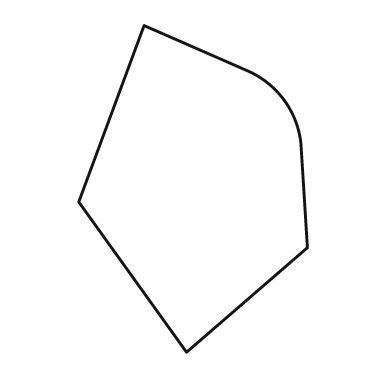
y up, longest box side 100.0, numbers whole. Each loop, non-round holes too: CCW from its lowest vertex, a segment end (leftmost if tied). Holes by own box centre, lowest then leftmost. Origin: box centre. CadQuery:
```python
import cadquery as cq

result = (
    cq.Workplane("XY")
    .moveTo(-2.0, -50.0)
    .lineTo(35.0, -18.0)
    .lineTo(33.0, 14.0)
    .threePointArc((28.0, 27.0), (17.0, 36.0))
    .lineTo(-15.0, 50.0)
    .lineTo(-35.0, -4.0)
    .close()
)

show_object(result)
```